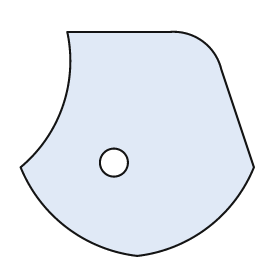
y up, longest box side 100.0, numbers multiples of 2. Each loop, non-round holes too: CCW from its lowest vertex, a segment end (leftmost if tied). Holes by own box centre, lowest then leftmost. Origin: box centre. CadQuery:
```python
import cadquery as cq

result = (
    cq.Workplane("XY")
    .moveTo(0.0, -48.0)
    .threePointArc((30.0, -36.0), (50.0, -10.0))
    .lineTo(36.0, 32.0)
    .threePointArc((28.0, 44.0), (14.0, 48.0))
    .lineTo(-30.0, 48.0)
    .threePointArc((-32.0, 16.0), (-50.0, -10.0))
    .threePointArc((-30.0, -36.0), (0.0, -48.0))
    .close()
    .moveTo(-10.0, -8.0)
    .circle(6.0)
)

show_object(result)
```